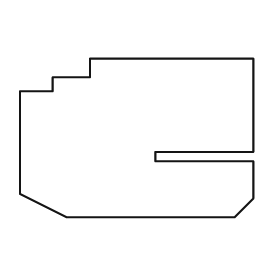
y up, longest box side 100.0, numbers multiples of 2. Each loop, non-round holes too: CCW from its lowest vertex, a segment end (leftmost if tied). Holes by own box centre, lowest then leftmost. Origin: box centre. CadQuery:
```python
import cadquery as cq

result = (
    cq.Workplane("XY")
    .moveTo(-30.0, -34.0)
    .lineTo(42.0, -34.0)
    .lineTo(50.0, -26.0)
    .lineTo(50.0, -10.0)
    .lineTo(8.0, -10.0)
    .lineTo(8.0, -6.0)
    .lineTo(50.0, -6.0)
    .lineTo(50.0, 34.0)
    .lineTo(-20.0, 34.0)
    .lineTo(-20.0, 26.0)
    .lineTo(-36.0, 26.0)
    .lineTo(-36.0, 20.0)
    .lineTo(-50.0, 20.0)
    .lineTo(-50.0, -24.0)
    .close()
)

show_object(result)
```